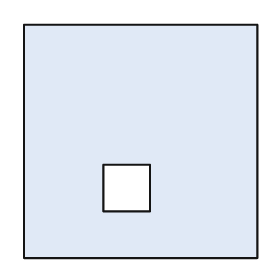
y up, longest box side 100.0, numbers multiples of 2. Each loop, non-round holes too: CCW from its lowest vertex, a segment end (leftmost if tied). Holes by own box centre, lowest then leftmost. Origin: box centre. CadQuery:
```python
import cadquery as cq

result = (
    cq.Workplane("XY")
    .moveTo(-50.0, -50.0)
    .lineTo(50.0, -50.0)
    .lineTo(50.0, 50.0)
    .lineTo(-50.0, 50.0)
    .close()
    .moveTo(-16.0, -30.0)
    .lineTo(4.0, -30.0)
    .lineTo(4.0, -10.0)
    .lineTo(-16.0, -10.0)
    .close()
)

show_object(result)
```